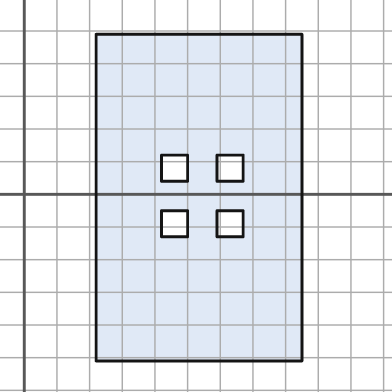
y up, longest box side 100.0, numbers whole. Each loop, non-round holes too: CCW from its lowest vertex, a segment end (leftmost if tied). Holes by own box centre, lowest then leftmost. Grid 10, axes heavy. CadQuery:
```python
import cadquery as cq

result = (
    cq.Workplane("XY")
    .moveTo(22.0, -51.0)
    .lineTo(85.0, -51.0)
    .lineTo(85.0, 49.0)
    .lineTo(22.0, 49.0)
    .close()
    .moveTo(42.0, -13.0)
    .lineTo(50.0, -13.0)
    .lineTo(50.0, -5.0)
    .lineTo(42.0, -5.0)
    .close()
    .moveTo(59.0, -13.0)
    .lineTo(67.0, -13.0)
    .lineTo(67.0, -5.0)
    .lineTo(59.0, -5.0)
    .close()
    .moveTo(42.0, 4.0)
    .lineTo(50.0, 4.0)
    .lineTo(50.0, 12.0)
    .lineTo(42.0, 12.0)
    .close()
    .moveTo(59.0, 4.0)
    .lineTo(67.0, 4.0)
    .lineTo(67.0, 12.0)
    .lineTo(59.0, 12.0)
    .close()
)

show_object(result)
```